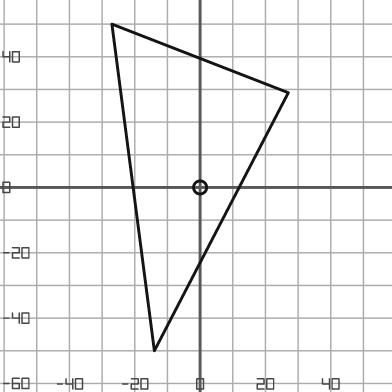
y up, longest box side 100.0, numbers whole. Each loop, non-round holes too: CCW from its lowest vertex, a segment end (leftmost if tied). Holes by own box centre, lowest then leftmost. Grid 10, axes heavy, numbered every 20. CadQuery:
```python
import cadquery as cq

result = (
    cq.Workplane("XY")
    .moveTo(-14.0, -50.0)
    .lineTo(27.0, 29.0)
    .lineTo(-27.0, 50.0)
    .close()
    .moveTo(0.0, 0.0)
    .circle(2.0)
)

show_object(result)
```